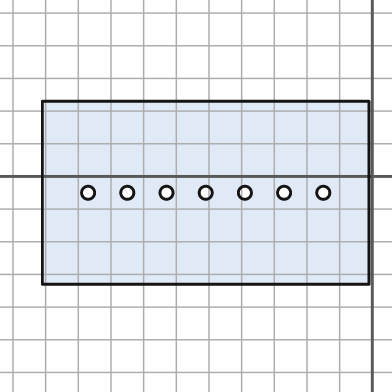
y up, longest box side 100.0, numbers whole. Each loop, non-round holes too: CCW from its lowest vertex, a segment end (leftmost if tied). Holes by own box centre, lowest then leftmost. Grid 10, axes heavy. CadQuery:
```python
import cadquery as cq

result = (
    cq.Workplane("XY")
    .moveTo(-101.0, -33.0)
    .lineTo(-1.0, -33.0)
    .lineTo(-1.0, 23.0)
    .lineTo(-101.0, 23.0)
    .close()
    .moveTo(-87.0, -5.0)
    .circle(2.0)
    .moveTo(-75.0, -5.0)
    .circle(2.0)
    .moveTo(-63.0, -5.0)
    .circle(2.0)
    .moveTo(-51.0, -5.0)
    .circle(2.0)
    .moveTo(-39.0, -5.0)
    .circle(2.0)
    .moveTo(-27.0, -5.0)
    .circle(2.0)
    .moveTo(-15.0, -5.0)
    .circle(2.0)
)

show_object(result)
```